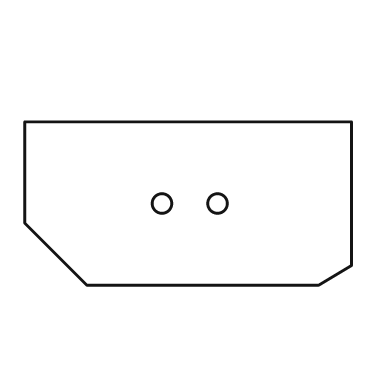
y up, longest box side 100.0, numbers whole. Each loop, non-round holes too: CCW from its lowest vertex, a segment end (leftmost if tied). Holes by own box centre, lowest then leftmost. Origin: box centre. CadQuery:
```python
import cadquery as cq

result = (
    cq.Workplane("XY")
    .moveTo(-31.0, -25.0)
    .lineTo(40.0, -25.0)
    .lineTo(50.0, -19.0)
    .lineTo(50.0, 25.0)
    .lineTo(-50.0, 25.0)
    .lineTo(-50.0, -6.0)
    .close()
    .moveTo(-8.0, 0.0)
    .circle(3.0)
    .moveTo(9.0, 0.0)
    .circle(3.0)
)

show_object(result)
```